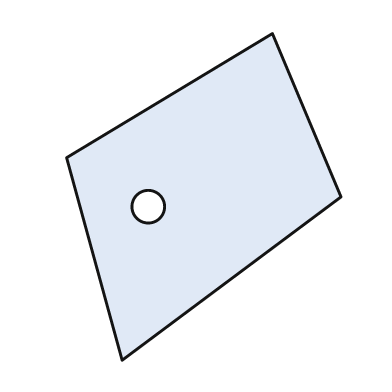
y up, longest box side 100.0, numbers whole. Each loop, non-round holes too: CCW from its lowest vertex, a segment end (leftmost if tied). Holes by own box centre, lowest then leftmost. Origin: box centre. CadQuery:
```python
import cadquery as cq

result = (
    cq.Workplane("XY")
    .moveTo(-25.0, -50.0)
    .lineTo(42.0, 0.0)
    .lineTo(21.0, 50.0)
    .lineTo(-42.0, 12.0)
    .close()
    .moveTo(-17.0, -3.0)
    .circle(5.0)
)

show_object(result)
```